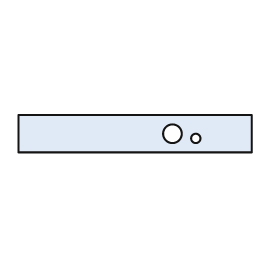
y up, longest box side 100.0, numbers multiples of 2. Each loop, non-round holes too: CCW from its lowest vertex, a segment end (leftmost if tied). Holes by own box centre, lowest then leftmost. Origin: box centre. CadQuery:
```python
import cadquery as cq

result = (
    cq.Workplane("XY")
    .moveTo(-50.0, -8.0)
    .lineTo(50.0, -8.0)
    .lineTo(50.0, 8.0)
    .lineTo(-50.0, 8.0)
    .close()
    .moveTo(26.0, -2.0)
    .circle(2.0)
    .moveTo(16.0, 0.0)
    .circle(4.0)
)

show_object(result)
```